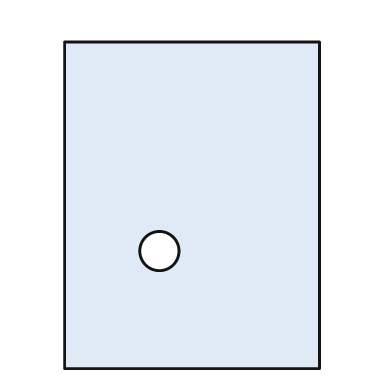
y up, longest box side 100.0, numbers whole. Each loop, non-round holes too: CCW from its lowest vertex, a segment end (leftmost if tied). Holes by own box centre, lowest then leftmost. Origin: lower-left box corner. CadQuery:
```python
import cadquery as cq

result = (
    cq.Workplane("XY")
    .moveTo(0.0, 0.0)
    .lineTo(78.0, 0.0)
    .lineTo(78.0, 100.0)
    .lineTo(0.0, 100.0)
    .close()
    .moveTo(29.0, 36.0)
    .circle(6.0)
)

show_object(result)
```